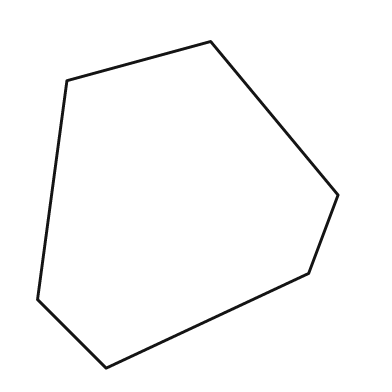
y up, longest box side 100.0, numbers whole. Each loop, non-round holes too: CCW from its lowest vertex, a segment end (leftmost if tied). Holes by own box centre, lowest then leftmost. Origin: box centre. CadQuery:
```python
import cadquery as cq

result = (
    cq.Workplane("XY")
    .moveTo(-25.0, -50.0)
    .lineTo(37.0, -21.0)
    .lineTo(46.0, 3.0)
    .lineTo(7.0, 50.0)
    .lineTo(-37.0, 38.0)
    .lineTo(-46.0, -29.0)
    .close()
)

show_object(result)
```